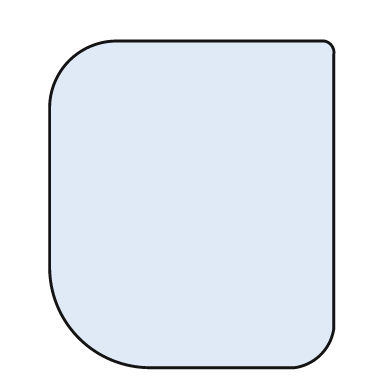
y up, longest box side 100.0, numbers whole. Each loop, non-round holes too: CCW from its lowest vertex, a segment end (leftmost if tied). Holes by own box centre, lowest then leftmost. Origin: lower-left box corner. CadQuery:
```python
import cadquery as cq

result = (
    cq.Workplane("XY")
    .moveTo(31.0, 0.0)
    .lineTo(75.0, 0.0)
    .threePointArc((83.0, 4.0), (87.0, 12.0))
    .lineTo(87.0, 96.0)
    .threePointArc((86.0, 99.0), (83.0, 100.0))
    .lineTo(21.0, 100.0)
    .threePointArc((6.0, 94.0), (0.0, 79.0))
    .lineTo(0.0, 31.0)
    .threePointArc((9.0, 9.0), (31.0, 0.0))
    .close()
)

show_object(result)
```